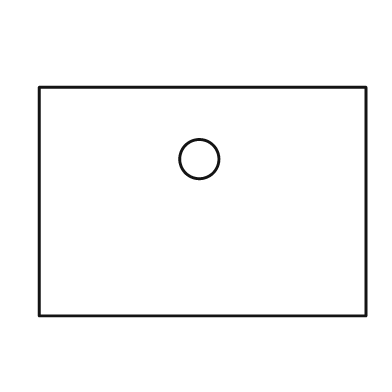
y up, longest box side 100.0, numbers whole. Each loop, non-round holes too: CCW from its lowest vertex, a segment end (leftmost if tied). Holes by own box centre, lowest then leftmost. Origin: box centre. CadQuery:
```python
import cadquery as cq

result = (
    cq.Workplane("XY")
    .moveTo(-50.0, -35.0)
    .lineTo(50.0, -35.0)
    .lineTo(50.0, 35.0)
    .lineTo(-50.0, 35.0)
    .close()
    .moveTo(-1.0, 13.0)
    .circle(6.0)
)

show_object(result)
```